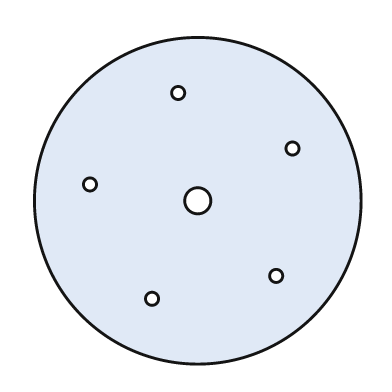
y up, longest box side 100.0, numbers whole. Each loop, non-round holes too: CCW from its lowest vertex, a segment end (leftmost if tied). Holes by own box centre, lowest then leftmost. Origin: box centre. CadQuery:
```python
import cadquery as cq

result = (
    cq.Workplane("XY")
    .moveTo(0.0, 0.0)
    .circle(50.0)
    .moveTo(-14.0, -30.0)
    .circle(2.0)
    .moveTo(24.0, -23.0)
    .circle(2.0)
    .moveTo(0.0, 0.0)
    .circle(4.0)
    .moveTo(-33.0, 5.0)
    .circle(2.0)
    .moveTo(29.0, 16.0)
    .circle(2.0)
    .moveTo(-6.0, 33.0)
    .circle(2.0)
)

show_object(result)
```